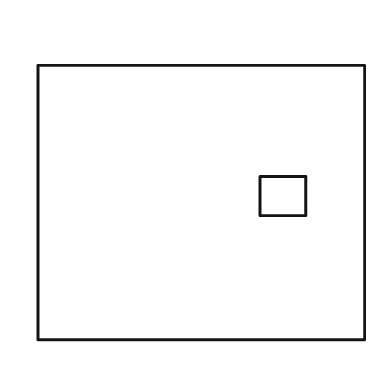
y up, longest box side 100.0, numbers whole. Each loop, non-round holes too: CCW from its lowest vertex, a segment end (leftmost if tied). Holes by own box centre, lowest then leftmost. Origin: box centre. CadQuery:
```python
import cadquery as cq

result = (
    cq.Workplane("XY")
    .moveTo(-50.0, -42.0)
    .lineTo(50.0, -42.0)
    .lineTo(50.0, 42.0)
    .lineTo(-50.0, 42.0)
    .close()
    .moveTo(18.0, -4.0)
    .lineTo(32.0, -4.0)
    .lineTo(32.0, 8.0)
    .lineTo(18.0, 8.0)
    .close()
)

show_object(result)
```